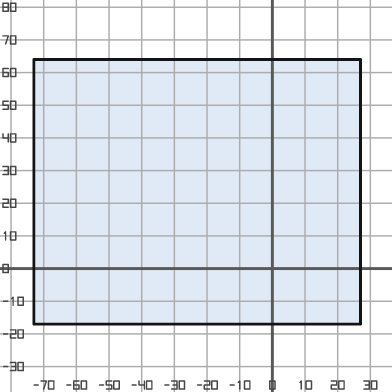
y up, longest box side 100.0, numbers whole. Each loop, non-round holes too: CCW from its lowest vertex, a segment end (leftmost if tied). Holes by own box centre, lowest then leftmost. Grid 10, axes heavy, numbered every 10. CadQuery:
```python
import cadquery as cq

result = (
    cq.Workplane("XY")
    .moveTo(-73.0, -17.0)
    .lineTo(27.0, -17.0)
    .lineTo(27.0, 64.0)
    .lineTo(-73.0, 64.0)
    .close()
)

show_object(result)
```